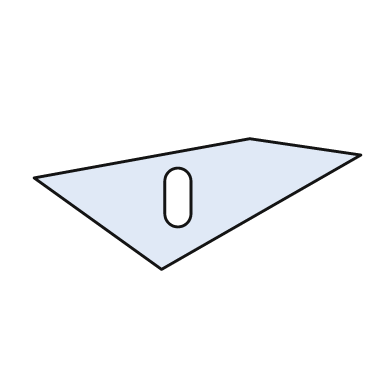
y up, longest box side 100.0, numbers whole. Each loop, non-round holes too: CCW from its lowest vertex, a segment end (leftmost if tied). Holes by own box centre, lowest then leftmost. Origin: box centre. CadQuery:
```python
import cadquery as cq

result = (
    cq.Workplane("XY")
    .moveTo(-11.0, -20.0)
    .lineTo(50.0, 15.0)
    .lineTo(16.0, 20.0)
    .lineTo(-50.0, 8.0)
    .close()
    .moveTo(-10.0, -3.0)
    .threePointArc((-6.0, -7.0), (-2.0, -3.0))
    .lineTo(-2.0, 7.0)
    .threePointArc((-6.0, 11.0), (-10.0, 7.0))
    .close()
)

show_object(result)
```